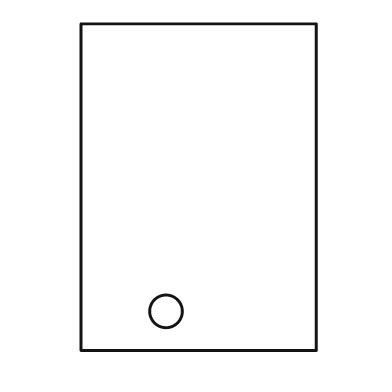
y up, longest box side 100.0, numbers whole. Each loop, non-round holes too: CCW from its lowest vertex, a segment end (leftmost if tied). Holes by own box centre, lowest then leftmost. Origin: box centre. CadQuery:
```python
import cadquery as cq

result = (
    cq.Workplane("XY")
    .moveTo(-36.0, -50.0)
    .lineTo(36.0, -50.0)
    .lineTo(36.0, 50.0)
    .lineTo(-36.0, 50.0)
    .close()
    .moveTo(-10.0, -38.0)
    .circle(5.0)
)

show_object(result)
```